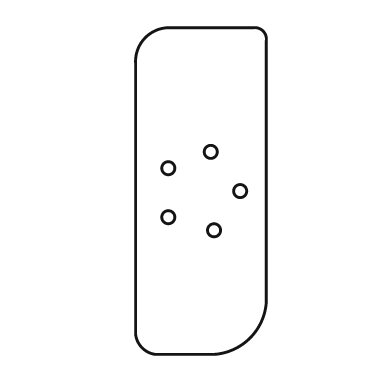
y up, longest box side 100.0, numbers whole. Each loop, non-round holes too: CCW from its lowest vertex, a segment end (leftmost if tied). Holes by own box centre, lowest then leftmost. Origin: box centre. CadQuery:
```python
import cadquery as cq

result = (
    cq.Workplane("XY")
    .moveTo(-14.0, -50.0)
    .lineTo(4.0, -50.0)
    .threePointArc((15.0, -45.0), (20.0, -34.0))
    .lineTo(20.0, 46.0)
    .threePointArc((19.0, 49.0), (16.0, 50.0))
    .lineTo(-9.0, 50.0)
    .threePointArc((-17.0, 47.0), (-20.0, 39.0))
    .lineTo(-20.0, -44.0)
    .threePointArc((-18.0, -48.0), (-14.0, -50.0))
    .close()
    .moveTo(4.0, -12.0)
    .circle(2.0)
    .moveTo(-10.0, -8.0)
    .circle(2.0)
    .moveTo(12.0, 0.0)
    .circle(2.0)
    .moveTo(-10.0, 7.0)
    .circle(2.0)
    .moveTo(3.0, 12.0)
    .circle(2.0)
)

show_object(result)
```